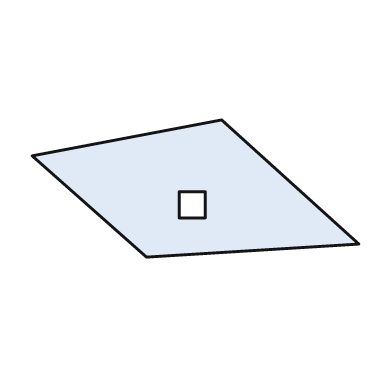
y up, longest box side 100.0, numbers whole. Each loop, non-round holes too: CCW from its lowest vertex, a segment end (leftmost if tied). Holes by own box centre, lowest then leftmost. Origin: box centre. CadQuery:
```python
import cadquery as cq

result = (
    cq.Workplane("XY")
    .moveTo(-15.0, -21.0)
    .lineTo(50.0, -17.0)
    .lineTo(8.0, 21.0)
    .lineTo(-50.0, 10.0)
    .close()
    .moveTo(-5.0, -9.0)
    .lineTo(3.0, -9.0)
    .lineTo(3.0, -1.0)
    .lineTo(-5.0, -1.0)
    .close()
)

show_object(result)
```